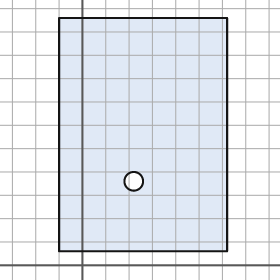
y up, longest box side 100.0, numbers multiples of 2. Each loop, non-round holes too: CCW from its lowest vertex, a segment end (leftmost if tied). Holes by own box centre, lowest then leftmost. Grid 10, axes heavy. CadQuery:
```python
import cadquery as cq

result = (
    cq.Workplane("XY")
    .moveTo(-10.0, 6.0)
    .lineTo(62.0, 6.0)
    .lineTo(62.0, 106.0)
    .lineTo(-10.0, 106.0)
    .close()
    .moveTo(22.0, 36.0)
    .circle(4.0)
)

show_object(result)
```